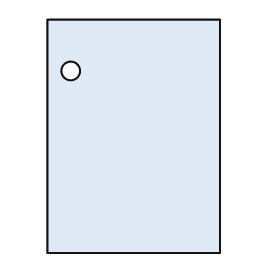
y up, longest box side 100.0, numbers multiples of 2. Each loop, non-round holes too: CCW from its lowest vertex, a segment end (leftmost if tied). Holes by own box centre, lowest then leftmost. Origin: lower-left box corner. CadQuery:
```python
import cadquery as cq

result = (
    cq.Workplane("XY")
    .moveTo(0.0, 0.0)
    .lineTo(74.0, 0.0)
    .lineTo(74.0, 100.0)
    .lineTo(0.0, 100.0)
    .close()
    .moveTo(10.0, 78.0)
    .circle(4.0)
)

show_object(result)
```